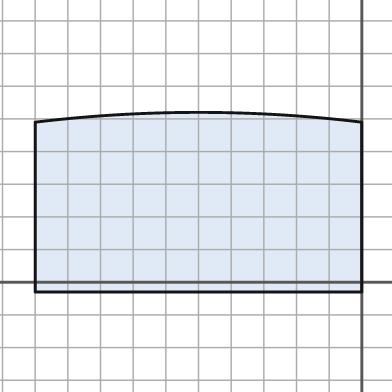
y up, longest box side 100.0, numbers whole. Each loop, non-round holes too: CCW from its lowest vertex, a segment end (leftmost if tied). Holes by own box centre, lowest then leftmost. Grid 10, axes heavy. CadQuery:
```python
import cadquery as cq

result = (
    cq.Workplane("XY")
    .moveTo(-100.0, -3.0)
    .lineTo(0.0, -3.0)
    .lineTo(0.0, 49.0)
    .threePointArc((-50.0, 52.0), (-100.0, 49.0))
    .close()
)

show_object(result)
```